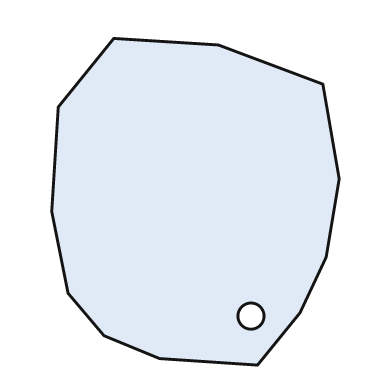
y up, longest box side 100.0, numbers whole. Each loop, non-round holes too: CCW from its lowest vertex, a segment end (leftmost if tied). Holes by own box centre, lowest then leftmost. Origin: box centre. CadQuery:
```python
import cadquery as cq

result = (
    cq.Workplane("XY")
    .moveTo(19.0, -50.0)
    .lineTo(32.0, -34.0)
    .lineTo(40.0, -17.0)
    .lineTo(44.0, 7.0)
    .lineTo(39.0, 36.0)
    .lineTo(7.0, 48.0)
    .lineTo(-25.0, 50.0)
    .lineTo(-42.0, 29.0)
    .lineTo(-44.0, -3.0)
    .lineTo(-39.0, -28.0)
    .lineTo(-28.0, -41.0)
    .lineTo(-11.0, -48.0)
    .close()
    .moveTo(17.0, -35.0)
    .circle(4.0)
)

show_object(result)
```